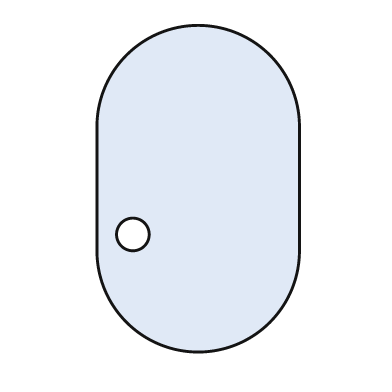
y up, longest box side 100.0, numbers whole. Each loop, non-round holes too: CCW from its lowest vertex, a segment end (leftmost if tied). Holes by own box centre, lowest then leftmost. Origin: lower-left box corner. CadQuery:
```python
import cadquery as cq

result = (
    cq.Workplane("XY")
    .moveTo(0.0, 31.0)
    .threePointArc((31.0, 0.0), (62.0, 31.0))
    .lineTo(62.0, 69.0)
    .threePointArc((31.0, 100.0), (0.0, 69.0))
    .close()
    .moveTo(11.0, 36.0)
    .circle(5.0)
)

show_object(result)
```